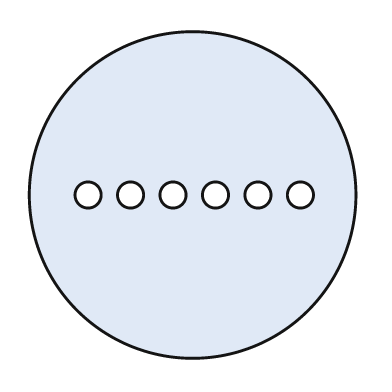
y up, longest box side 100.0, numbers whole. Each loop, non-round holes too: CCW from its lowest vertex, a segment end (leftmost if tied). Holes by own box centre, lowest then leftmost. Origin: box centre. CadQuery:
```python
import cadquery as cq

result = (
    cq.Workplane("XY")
    .moveTo(0.0, 0.0)
    .circle(50.0)
    .moveTo(-32.0, 0.0)
    .circle(4.0)
    .moveTo(-19.0, 0.0)
    .circle(4.0)
    .moveTo(-6.0, 0.0)
    .circle(4.0)
    .moveTo(7.0, 0.0)
    .circle(4.0)
    .moveTo(20.0, 0.0)
    .circle(4.0)
    .moveTo(33.0, 0.0)
    .circle(4.0)
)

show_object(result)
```